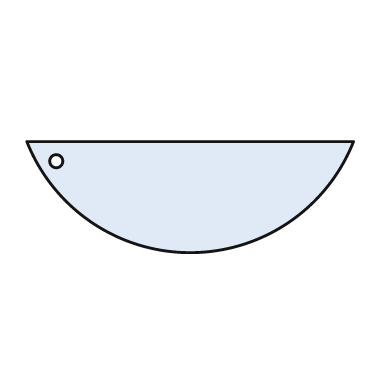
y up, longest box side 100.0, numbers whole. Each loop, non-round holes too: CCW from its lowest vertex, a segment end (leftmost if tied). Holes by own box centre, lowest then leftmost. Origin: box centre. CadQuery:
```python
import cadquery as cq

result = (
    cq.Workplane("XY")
    .moveTo(-50.0, 17.0)
    .threePointArc((0.0, -17.0), (50.0, 17.0))
    .close()
    .moveTo(-41.0, 11.0)
    .circle(2.0)
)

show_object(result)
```